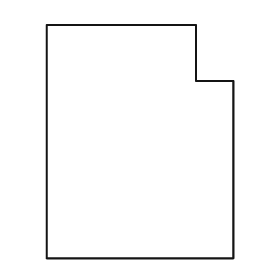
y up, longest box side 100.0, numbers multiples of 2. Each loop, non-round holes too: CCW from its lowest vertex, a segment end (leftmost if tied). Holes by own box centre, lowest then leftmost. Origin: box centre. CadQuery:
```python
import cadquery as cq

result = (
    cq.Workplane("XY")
    .moveTo(-40.0, -50.0)
    .lineTo(40.0, -50.0)
    .lineTo(40.0, 26.0)
    .lineTo(24.0, 26.0)
    .lineTo(24.0, 50.0)
    .lineTo(-40.0, 50.0)
    .close()
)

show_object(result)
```